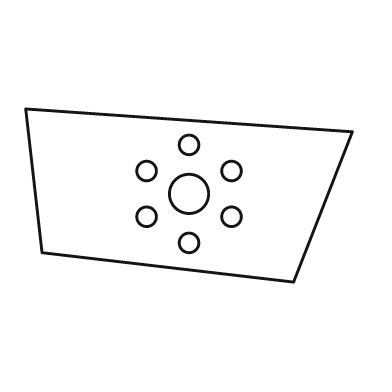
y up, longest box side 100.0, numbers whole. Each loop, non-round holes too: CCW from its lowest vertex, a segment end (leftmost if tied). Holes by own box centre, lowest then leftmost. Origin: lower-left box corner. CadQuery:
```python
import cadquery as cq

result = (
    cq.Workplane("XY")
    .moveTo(82.0, 0.0)
    .lineTo(100.0, 46.0)
    .lineTo(0.0, 53.0)
    .lineTo(5.0, 9.0)
    .close()
    .moveTo(50.0, 12.0)
    .circle(3.0)
    .moveTo(37.0, 20.0)
    .circle(3.0)
    .moveTo(63.0, 20.0)
    .circle(3.0)
    .moveTo(50.0, 27.0)
    .circle(6.0)
    .moveTo(37.0, 34.0)
    .circle(3.0)
    .moveTo(63.0, 34.0)
    .circle(3.0)
    .moveTo(50.0, 42.0)
    .circle(3.0)
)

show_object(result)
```